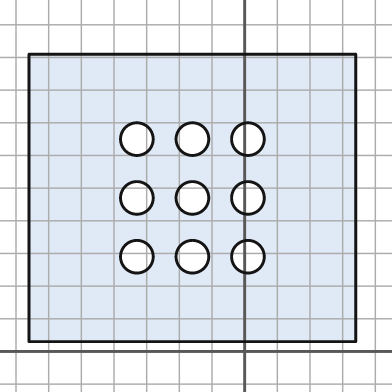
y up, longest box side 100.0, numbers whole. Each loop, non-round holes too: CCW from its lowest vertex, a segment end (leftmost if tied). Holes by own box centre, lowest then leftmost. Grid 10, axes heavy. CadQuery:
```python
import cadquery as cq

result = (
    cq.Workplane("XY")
    .moveTo(-66.0, 3.0)
    .lineTo(34.0, 3.0)
    .lineTo(34.0, 91.0)
    .lineTo(-66.0, 91.0)
    .close()
    .moveTo(-33.0, 29.0)
    .circle(5.0)
    .moveTo(-16.0, 29.0)
    .circle(5.0)
    .moveTo(1.0, 29.0)
    .circle(5.0)
    .moveTo(-33.0, 47.0)
    .circle(5.0)
    .moveTo(-16.0, 47.0)
    .circle(5.0)
    .moveTo(1.0, 47.0)
    .circle(5.0)
    .moveTo(-33.0, 65.0)
    .circle(5.0)
    .moveTo(-16.0, 65.0)
    .circle(5.0)
    .moveTo(1.0, 65.0)
    .circle(5.0)
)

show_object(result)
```